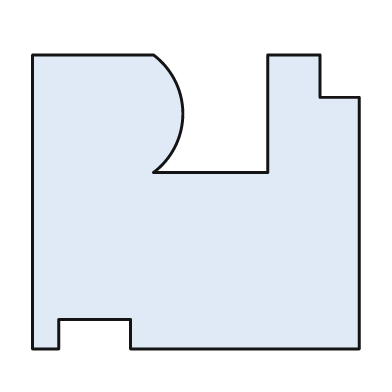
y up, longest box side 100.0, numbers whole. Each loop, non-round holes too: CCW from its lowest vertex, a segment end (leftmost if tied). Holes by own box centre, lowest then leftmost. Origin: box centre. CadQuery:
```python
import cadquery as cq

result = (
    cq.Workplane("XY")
    .moveTo(-50.0, -45.0)
    .lineTo(-42.0, -45.0)
    .lineTo(-42.0, -36.0)
    .lineTo(-20.0, -36.0)
    .lineTo(-20.0, -45.0)
    .lineTo(50.0, -45.0)
    .lineTo(50.0, 32.0)
    .lineTo(38.0, 32.0)
    .lineTo(38.0, 45.0)
    .lineTo(22.0, 45.0)
    .lineTo(22.0, 9.0)
    .lineTo(-13.0, 9.0)
    .threePointArc((-4.0, 27.0), (-13.0, 45.0))
    .lineTo(-50.0, 45.0)
    .close()
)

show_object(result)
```